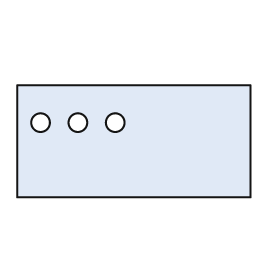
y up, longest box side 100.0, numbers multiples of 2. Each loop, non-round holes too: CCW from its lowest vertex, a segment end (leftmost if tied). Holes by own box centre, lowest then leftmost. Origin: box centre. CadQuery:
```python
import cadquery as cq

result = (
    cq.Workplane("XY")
    .moveTo(-50.0, -24.0)
    .lineTo(50.0, -24.0)
    .lineTo(50.0, 24.0)
    .lineTo(-50.0, 24.0)
    .close()
    .moveTo(-40.0, 8.0)
    .circle(4.0)
    .moveTo(-24.0, 8.0)
    .circle(4.0)
    .moveTo(-8.0, 8.0)
    .circle(4.0)
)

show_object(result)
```